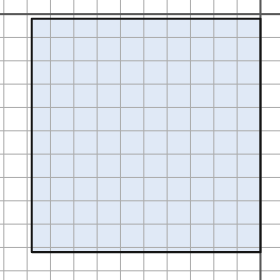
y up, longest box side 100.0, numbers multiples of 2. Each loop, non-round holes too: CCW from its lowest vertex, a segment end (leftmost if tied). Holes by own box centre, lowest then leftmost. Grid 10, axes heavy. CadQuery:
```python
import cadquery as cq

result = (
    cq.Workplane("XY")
    .moveTo(-98.0, -102.0)
    .lineTo(0.0, -102.0)
    .lineTo(0.0, -2.0)
    .lineTo(-98.0, -2.0)
    .close()
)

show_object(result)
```